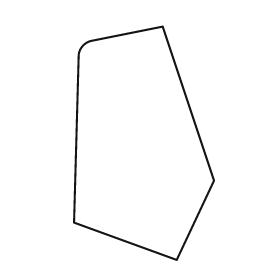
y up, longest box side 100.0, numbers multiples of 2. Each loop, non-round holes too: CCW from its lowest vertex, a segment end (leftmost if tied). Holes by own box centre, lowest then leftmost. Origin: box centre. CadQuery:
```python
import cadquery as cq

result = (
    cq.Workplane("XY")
    .moveTo(14.0, -50.0)
    .lineTo(30.0, -16.0)
    .lineTo(8.0, 50.0)
    .lineTo(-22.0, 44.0)
    .threePointArc((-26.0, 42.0), (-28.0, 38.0))
    .lineTo(-30.0, -34.0)
    .close()
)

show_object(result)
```